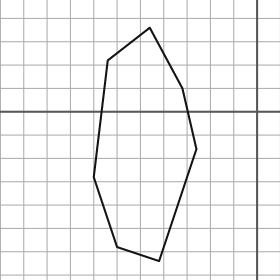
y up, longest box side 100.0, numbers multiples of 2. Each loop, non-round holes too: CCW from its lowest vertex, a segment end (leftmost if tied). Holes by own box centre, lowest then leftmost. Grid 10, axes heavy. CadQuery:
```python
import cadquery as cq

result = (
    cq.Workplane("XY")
    .moveTo(-42.0, -64.0)
    .lineTo(-26.0, -16.0)
    .lineTo(-32.0, 10.0)
    .lineTo(-46.0, 36.0)
    .lineTo(-64.0, 22.0)
    .lineTo(-70.0, -28.0)
    .lineTo(-60.0, -58.0)
    .close()
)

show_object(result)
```